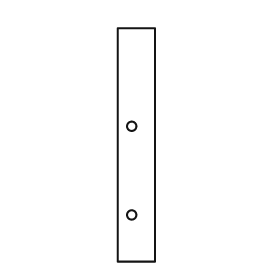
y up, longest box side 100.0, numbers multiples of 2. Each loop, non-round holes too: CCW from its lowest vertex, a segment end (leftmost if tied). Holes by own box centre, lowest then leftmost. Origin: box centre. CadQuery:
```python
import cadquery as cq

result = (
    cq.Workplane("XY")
    .moveTo(-8.0, -50.0)
    .lineTo(8.0, -50.0)
    .lineTo(8.0, 50.0)
    .lineTo(-8.0, 50.0)
    .close()
    .moveTo(-2.0, -30.0)
    .circle(2.0)
    .moveTo(-2.0, 8.0)
    .circle(2.0)
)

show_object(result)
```